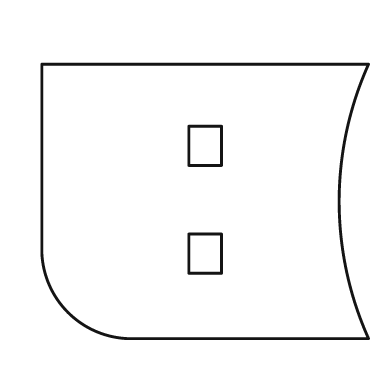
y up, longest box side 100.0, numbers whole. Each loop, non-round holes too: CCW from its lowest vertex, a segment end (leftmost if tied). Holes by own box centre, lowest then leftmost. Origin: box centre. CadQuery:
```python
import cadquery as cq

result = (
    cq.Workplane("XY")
    .moveTo(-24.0, -42.0)
    .lineTo(50.0, -42.0)
    .threePointArc((41.0, 0.0), (50.0, 42.0))
    .lineTo(-50.0, 42.0)
    .lineTo(-50.0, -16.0)
    .threePointArc((-42.0, -34.0), (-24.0, -42.0))
    .close()
    .moveTo(-5.0, -22.0)
    .lineTo(5.0, -22.0)
    .lineTo(5.0, -10.0)
    .lineTo(-5.0, -10.0)
    .close()
    .moveTo(-5.0, 11.0)
    .lineTo(5.0, 11.0)
    .lineTo(5.0, 23.0)
    .lineTo(-5.0, 23.0)
    .close()
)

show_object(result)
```